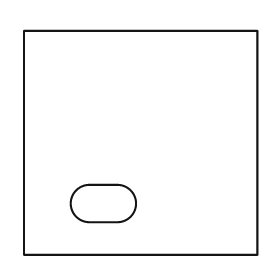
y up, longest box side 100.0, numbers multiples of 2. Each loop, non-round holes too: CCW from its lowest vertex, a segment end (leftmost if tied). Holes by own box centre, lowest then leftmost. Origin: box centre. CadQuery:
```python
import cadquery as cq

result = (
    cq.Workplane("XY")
    .moveTo(-50.0, -48.0)
    .lineTo(50.0, -48.0)
    .lineTo(50.0, 48.0)
    .lineTo(-50.0, 48.0)
    .close()
    .moveTo(-22.0, -34.0)
    .lineTo(-10.0, -34.0)
    .threePointArc((-2.0, -26.0), (-10.0, -18.0))
    .lineTo(-22.0, -18.0)
    .threePointArc((-30.0, -26.0), (-22.0, -34.0))
    .close()
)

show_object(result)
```